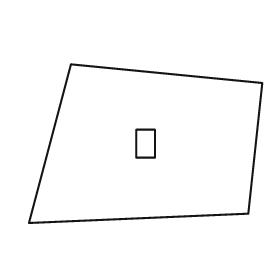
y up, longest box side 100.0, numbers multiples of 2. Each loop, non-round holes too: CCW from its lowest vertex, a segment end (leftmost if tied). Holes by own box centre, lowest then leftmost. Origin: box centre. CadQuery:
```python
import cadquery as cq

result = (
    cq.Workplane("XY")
    .moveTo(-50.0, -34.0)
    .lineTo(44.0, -30.0)
    .lineTo(50.0, 26.0)
    .lineTo(-32.0, 34.0)
    .close()
    .moveTo(-4.0, -6.0)
    .lineTo(4.0, -6.0)
    .lineTo(4.0, 6.0)
    .lineTo(-4.0, 6.0)
    .close()
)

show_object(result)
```